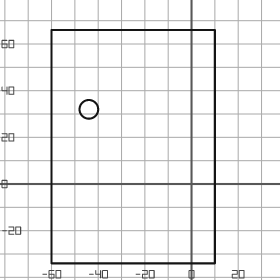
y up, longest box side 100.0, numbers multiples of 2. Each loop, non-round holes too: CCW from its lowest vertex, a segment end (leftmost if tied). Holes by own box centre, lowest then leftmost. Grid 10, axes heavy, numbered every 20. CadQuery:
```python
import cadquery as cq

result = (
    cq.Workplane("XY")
    .moveTo(-60.0, -34.0)
    .lineTo(10.0, -34.0)
    .lineTo(10.0, 66.0)
    .lineTo(-60.0, 66.0)
    .close()
    .moveTo(-44.0, 32.0)
    .circle(4.0)
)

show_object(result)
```